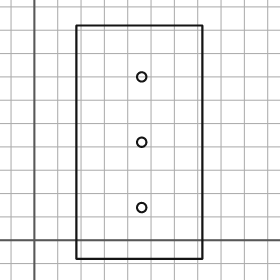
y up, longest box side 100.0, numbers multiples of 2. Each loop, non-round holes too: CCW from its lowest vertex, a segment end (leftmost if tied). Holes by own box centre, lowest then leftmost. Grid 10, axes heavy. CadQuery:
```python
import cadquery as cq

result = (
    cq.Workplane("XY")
    .moveTo(18.0, -8.0)
    .lineTo(72.0, -8.0)
    .lineTo(72.0, 92.0)
    .lineTo(18.0, 92.0)
    .close()
    .moveTo(46.0, 14.0)
    .circle(2.0)
    .moveTo(46.0, 42.0)
    .circle(2.0)
    .moveTo(46.0, 70.0)
    .circle(2.0)
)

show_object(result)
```